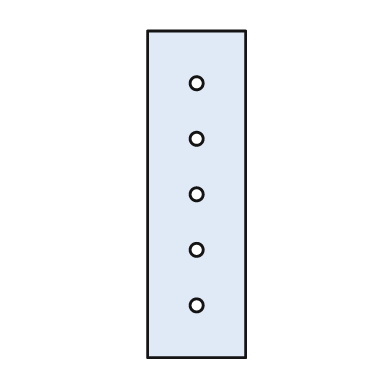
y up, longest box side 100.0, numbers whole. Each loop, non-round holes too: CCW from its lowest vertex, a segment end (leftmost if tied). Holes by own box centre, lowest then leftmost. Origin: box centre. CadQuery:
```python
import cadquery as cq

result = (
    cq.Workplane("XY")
    .moveTo(-15.0, -50.0)
    .lineTo(15.0, -50.0)
    .lineTo(15.0, 50.0)
    .lineTo(-15.0, 50.0)
    .close()
    .moveTo(0.0, -34.0)
    .circle(2.0)
    .moveTo(0.0, -17.0)
    .circle(2.0)
    .moveTo(0.0, 0.0)
    .circle(2.0)
    .moveTo(0.0, 17.0)
    .circle(2.0)
    .moveTo(0.0, 34.0)
    .circle(2.0)
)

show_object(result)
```